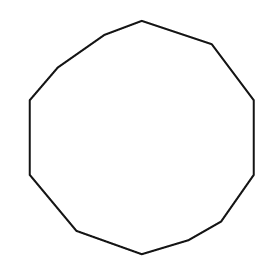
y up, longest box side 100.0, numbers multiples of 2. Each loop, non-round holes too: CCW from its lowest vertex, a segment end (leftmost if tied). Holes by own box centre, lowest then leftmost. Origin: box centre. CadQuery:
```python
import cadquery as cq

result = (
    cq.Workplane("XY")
    .moveTo(0.0, -50.0)
    .lineTo(20.0, -44.0)
    .lineTo(34.0, -36.0)
    .lineTo(48.0, -16.0)
    .lineTo(48.0, 16.0)
    .lineTo(30.0, 40.0)
    .lineTo(0.0, 50.0)
    .lineTo(-16.0, 44.0)
    .lineTo(-36.0, 30.0)
    .lineTo(-48.0, 16.0)
    .lineTo(-48.0, -16.0)
    .lineTo(-28.0, -40.0)
    .close()
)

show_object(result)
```